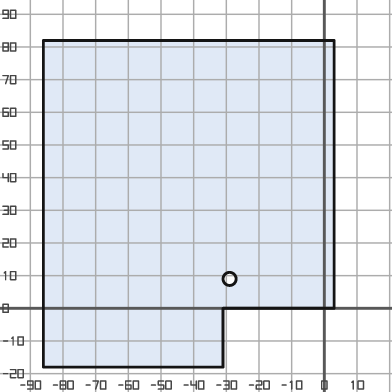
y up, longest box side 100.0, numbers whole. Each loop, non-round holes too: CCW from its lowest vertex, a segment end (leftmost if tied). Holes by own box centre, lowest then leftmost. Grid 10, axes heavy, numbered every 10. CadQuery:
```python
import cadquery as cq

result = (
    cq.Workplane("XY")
    .moveTo(-86.0, -18.0)
    .lineTo(-31.0, -18.0)
    .lineTo(-31.0, 0.0)
    .lineTo(3.0, 0.0)
    .lineTo(3.0, 82.0)
    .lineTo(-86.0, 82.0)
    .close()
    .moveTo(-29.0, 9.0)
    .circle(2.0)
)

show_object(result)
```